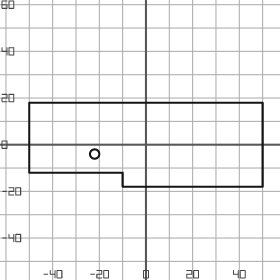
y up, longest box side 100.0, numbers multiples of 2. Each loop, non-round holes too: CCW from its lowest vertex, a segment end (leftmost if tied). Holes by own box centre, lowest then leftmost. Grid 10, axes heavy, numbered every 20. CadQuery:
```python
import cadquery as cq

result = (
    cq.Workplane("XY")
    .moveTo(-10.0, -18.0)
    .lineTo(50.0, -18.0)
    .lineTo(50.0, 18.0)
    .lineTo(-50.0, 18.0)
    .lineTo(-50.0, -12.0)
    .lineTo(-10.0, -12.0)
    .close()
    .moveTo(-22.0, -4.0)
    .circle(2.0)
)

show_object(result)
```